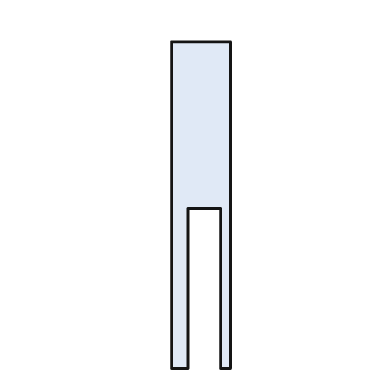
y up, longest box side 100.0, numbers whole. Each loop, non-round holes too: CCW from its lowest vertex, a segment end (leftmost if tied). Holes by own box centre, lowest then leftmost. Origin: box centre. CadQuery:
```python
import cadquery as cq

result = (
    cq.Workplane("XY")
    .moveTo(-9.0, -50.0)
    .lineTo(-4.0, -50.0)
    .lineTo(-4.0, -1.0)
    .lineTo(6.0, -1.0)
    .lineTo(6.0, -50.0)
    .lineTo(9.0, -50.0)
    .lineTo(9.0, 50.0)
    .lineTo(-9.0, 50.0)
    .close()
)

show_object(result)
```